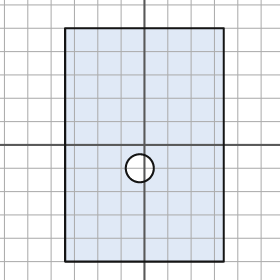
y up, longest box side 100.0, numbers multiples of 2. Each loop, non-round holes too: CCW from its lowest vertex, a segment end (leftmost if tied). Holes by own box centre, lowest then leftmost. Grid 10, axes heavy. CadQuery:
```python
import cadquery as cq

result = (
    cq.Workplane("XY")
    .moveTo(-34.0, -50.0)
    .lineTo(34.0, -50.0)
    .lineTo(34.0, 50.0)
    .lineTo(-34.0, 50.0)
    .close()
    .moveTo(-2.0, -10.0)
    .circle(6.0)
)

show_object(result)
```